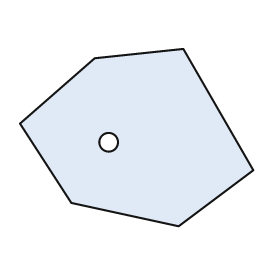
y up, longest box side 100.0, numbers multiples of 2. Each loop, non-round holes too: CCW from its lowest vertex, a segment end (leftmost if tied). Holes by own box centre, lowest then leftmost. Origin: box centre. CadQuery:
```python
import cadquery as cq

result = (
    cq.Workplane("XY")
    .moveTo(18.0, -38.0)
    .lineTo(50.0, -14.0)
    .lineTo(20.0, 38.0)
    .lineTo(-18.0, 34.0)
    .lineTo(-50.0, 6.0)
    .lineTo(-28.0, -28.0)
    .close()
    .moveTo(-12.0, -2.0)
    .circle(4.0)
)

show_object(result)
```